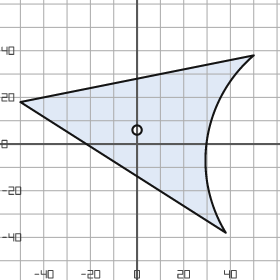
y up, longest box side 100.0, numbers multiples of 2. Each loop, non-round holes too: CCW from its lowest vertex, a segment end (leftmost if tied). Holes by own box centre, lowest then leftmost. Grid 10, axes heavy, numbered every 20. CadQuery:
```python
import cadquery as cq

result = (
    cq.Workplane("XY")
    .moveTo(38.0, -38.0)
    .threePointArc((30.0, 2.0), (50.0, 38.0))
    .lineTo(-50.0, 18.0)
    .close()
    .moveTo(0.0, 6.0)
    .circle(2.0)
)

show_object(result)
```